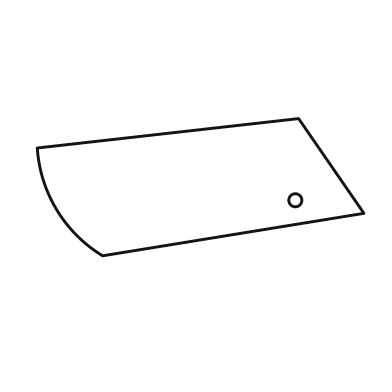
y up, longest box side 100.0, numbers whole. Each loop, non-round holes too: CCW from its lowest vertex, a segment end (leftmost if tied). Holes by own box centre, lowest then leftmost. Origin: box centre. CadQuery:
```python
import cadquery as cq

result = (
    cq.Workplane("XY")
    .moveTo(-30.0, -21.0)
    .lineTo(50.0, -8.0)
    .lineTo(30.0, 21.0)
    .lineTo(-50.0, 12.0)
    .threePointArc((-44.0, -7.0), (-30.0, -21.0))
    .close()
    .moveTo(29.0, -4.0)
    .circle(2.0)
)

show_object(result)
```